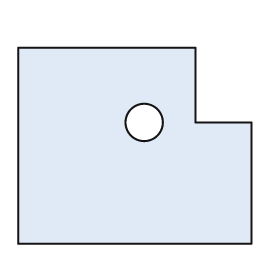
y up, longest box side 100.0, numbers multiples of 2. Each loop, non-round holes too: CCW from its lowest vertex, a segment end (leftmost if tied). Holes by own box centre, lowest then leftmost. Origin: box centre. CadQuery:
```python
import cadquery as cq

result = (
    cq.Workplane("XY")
    .moveTo(-50.0, -42.0)
    .lineTo(50.0, -42.0)
    .lineTo(50.0, 10.0)
    .lineTo(26.0, 10.0)
    .lineTo(26.0, 42.0)
    .lineTo(-50.0, 42.0)
    .close()
    .moveTo(4.0, 10.0)
    .circle(8.0)
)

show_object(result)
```